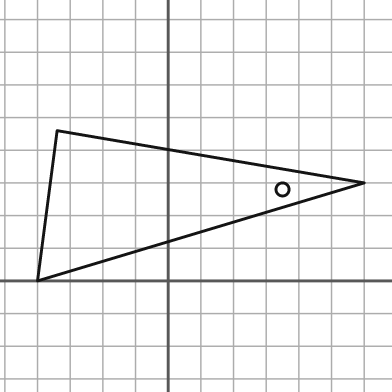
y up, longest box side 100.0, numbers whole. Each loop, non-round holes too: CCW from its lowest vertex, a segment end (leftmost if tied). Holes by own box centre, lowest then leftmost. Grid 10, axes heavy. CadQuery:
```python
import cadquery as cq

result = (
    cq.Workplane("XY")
    .moveTo(-40.0, 0.0)
    .lineTo(60.0, 30.0)
    .lineTo(-34.0, 46.0)
    .close()
    .moveTo(35.0, 28.0)
    .circle(2.0)
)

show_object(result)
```